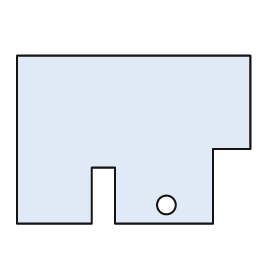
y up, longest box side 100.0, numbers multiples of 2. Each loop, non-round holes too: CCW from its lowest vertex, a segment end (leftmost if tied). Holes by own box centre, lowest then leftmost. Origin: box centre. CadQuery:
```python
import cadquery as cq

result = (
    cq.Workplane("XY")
    .moveTo(-50.0, -36.0)
    .lineTo(-18.0, -36.0)
    .lineTo(-18.0, -12.0)
    .lineTo(-8.0, -12.0)
    .lineTo(-8.0, -36.0)
    .lineTo(34.0, -36.0)
    .lineTo(34.0, -4.0)
    .lineTo(50.0, -4.0)
    .lineTo(50.0, 36.0)
    .lineTo(-50.0, 36.0)
    .close()
    .moveTo(14.0, -28.0)
    .circle(4.0)
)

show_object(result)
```